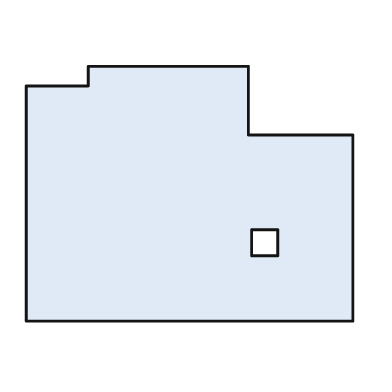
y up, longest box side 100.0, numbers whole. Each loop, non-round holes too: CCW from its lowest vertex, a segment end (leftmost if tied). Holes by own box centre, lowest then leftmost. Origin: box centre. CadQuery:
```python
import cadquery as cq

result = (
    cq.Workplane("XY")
    .moveTo(-50.0, -39.0)
    .lineTo(50.0, -39.0)
    .lineTo(50.0, 18.0)
    .lineTo(18.0, 18.0)
    .lineTo(18.0, 39.0)
    .lineTo(-31.0, 39.0)
    .lineTo(-31.0, 33.0)
    .lineTo(-50.0, 33.0)
    .close()
    .moveTo(19.0, -19.0)
    .lineTo(27.0, -19.0)
    .lineTo(27.0, -11.0)
    .lineTo(19.0, -11.0)
    .close()
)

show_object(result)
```